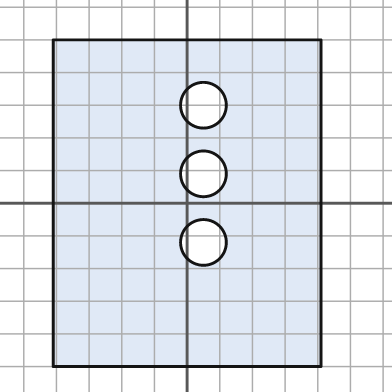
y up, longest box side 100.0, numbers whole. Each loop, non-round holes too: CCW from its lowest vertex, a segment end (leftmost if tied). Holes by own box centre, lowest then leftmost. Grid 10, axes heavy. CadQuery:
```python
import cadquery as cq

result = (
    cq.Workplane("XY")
    .moveTo(-41.0, -50.0)
    .lineTo(41.0, -50.0)
    .lineTo(41.0, 50.0)
    .lineTo(-41.0, 50.0)
    .close()
    .moveTo(5.0, -12.0)
    .circle(7.0)
    .moveTo(5.0, 9.0)
    .circle(7.0)
    .moveTo(5.0, 30.0)
    .circle(7.0)
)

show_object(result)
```